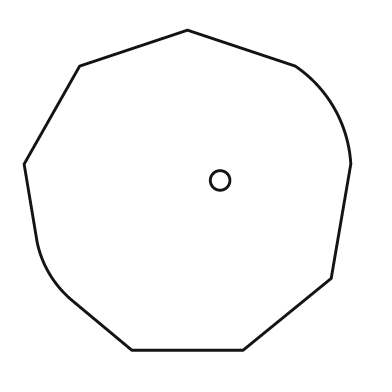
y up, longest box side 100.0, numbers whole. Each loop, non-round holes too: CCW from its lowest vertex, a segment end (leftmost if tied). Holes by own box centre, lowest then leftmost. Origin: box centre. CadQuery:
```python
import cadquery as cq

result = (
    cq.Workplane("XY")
    .moveTo(-17.0, -49.0)
    .lineTo(17.0, -49.0)
    .lineTo(44.0, -27.0)
    .lineTo(50.0, 8.0)
    .threePointArc((45.0, 25.0), (33.0, 38.0))
    .lineTo(0.0, 49.0)
    .lineTo(-33.0, 38.0)
    .lineTo(-50.0, 8.0)
    .lineTo(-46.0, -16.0)
    .threePointArc((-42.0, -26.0), (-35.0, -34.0))
    .close()
    .moveTo(10.0, 3.0)
    .circle(3.0)
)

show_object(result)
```